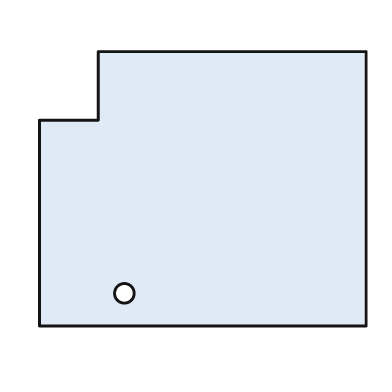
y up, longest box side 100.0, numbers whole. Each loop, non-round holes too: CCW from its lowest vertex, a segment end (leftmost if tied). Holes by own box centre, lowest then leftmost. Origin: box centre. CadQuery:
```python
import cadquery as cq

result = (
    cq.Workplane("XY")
    .moveTo(-50.0, -42.0)
    .lineTo(50.0, -42.0)
    .lineTo(50.0, 42.0)
    .lineTo(-32.0, 42.0)
    .lineTo(-32.0, 21.0)
    .lineTo(-50.0, 21.0)
    .close()
    .moveTo(-24.0, -32.0)
    .circle(3.0)
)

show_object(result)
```